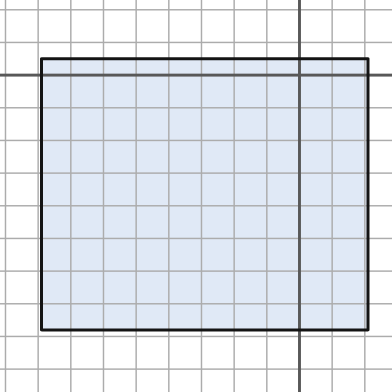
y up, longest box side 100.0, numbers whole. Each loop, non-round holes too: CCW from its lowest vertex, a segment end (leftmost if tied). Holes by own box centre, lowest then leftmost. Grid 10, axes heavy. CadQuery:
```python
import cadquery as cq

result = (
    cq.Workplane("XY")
    .moveTo(-79.0, -78.0)
    .lineTo(21.0, -78.0)
    .lineTo(21.0, 5.0)
    .lineTo(-79.0, 5.0)
    .close()
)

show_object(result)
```